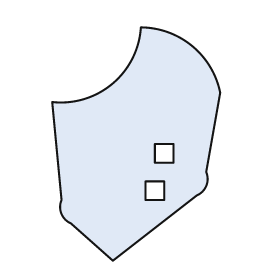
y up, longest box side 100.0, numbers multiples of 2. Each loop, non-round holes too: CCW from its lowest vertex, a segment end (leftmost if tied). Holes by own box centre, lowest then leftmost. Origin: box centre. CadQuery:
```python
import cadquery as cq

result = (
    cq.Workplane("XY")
    .moveTo(-10.0, -50.0)
    .lineTo(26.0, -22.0)
    .threePointArc((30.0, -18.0), (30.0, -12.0))
    .lineTo(36.0, 22.0)
    .threePointArc((24.0, 42.0), (2.0, 50.0))
    .threePointArc((-10.0, 26.0), (-36.0, 18.0))
    .lineTo(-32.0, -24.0)
    .threePointArc((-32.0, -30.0), (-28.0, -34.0))
    .close()
    .moveTo(4.0, -24.0)
    .lineTo(12.0, -24.0)
    .lineTo(12.0, -16.0)
    .lineTo(4.0, -16.0)
    .close()
    .moveTo(8.0, -8.0)
    .lineTo(16.0, -8.0)
    .lineTo(16.0, 0.0)
    .lineTo(8.0, 0.0)
    .close()
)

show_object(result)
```